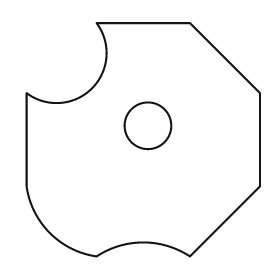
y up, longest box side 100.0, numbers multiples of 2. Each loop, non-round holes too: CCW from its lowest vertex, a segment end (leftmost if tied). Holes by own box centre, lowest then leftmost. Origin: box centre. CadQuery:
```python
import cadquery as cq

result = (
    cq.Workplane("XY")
    .moveTo(-20.0, -50.0)
    .threePointArc((0.0, -44.0), (20.0, -50.0))
    .lineTo(50.0, -20.0)
    .lineTo(50.0, 20.0)
    .lineTo(20.0, 50.0)
    .lineTo(-20.0, 50.0)
    .threePointArc((-22.0, 22.0), (-50.0, 20.0))
    .lineTo(-50.0, -20.0)
    .threePointArc((-40.0, -40.0), (-20.0, -50.0))
    .close()
    .moveTo(2.0, 6.0)
    .circle(10.0)
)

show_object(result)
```